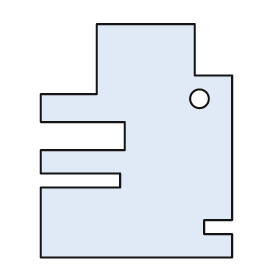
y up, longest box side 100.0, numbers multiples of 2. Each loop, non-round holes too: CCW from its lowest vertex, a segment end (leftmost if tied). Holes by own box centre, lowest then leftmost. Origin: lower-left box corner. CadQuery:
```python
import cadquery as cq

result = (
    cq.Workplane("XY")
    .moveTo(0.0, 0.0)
    .lineTo(82.0, 0.0)
    .lineTo(82.0, 10.0)
    .lineTo(70.0, 10.0)
    .lineTo(70.0, 16.0)
    .lineTo(82.0, 16.0)
    .lineTo(82.0, 78.0)
    .lineTo(66.0, 78.0)
    .lineTo(66.0, 100.0)
    .lineTo(24.0, 100.0)
    .lineTo(24.0, 70.0)
    .lineTo(0.0, 70.0)
    .lineTo(0.0, 58.0)
    .lineTo(36.0, 58.0)
    .lineTo(36.0, 46.0)
    .lineTo(0.0, 46.0)
    .lineTo(0.0, 36.0)
    .lineTo(34.0, 36.0)
    .lineTo(34.0, 30.0)
    .lineTo(0.0, 30.0)
    .close()
    .moveTo(68.0, 68.0)
    .circle(4.0)
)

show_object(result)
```